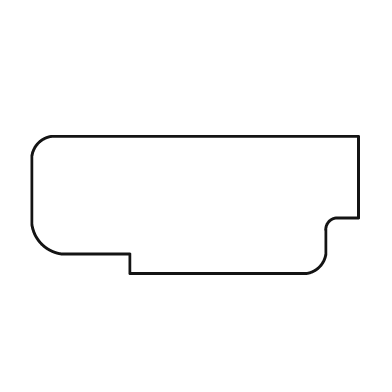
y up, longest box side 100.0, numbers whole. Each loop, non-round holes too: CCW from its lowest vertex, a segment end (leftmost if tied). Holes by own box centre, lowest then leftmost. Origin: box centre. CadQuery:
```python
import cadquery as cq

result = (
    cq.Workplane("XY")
    .moveTo(-20.0, -21.0)
    .lineTo(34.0, -21.0)
    .threePointArc((38.0, -19.0), (40.0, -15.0))
    .lineTo(40.0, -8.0)
    .threePointArc((41.0, -5.0), (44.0, -4.0))
    .lineTo(50.0, -4.0)
    .lineTo(50.0, 21.0)
    .lineTo(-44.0, 21.0)
    .threePointArc((-48.0, 19.0), (-50.0, 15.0))
    .lineTo(-50.0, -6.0)
    .threePointArc((-47.0, -12.0), (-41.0, -15.0))
    .lineTo(-20.0, -15.0)
    .close()
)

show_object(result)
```